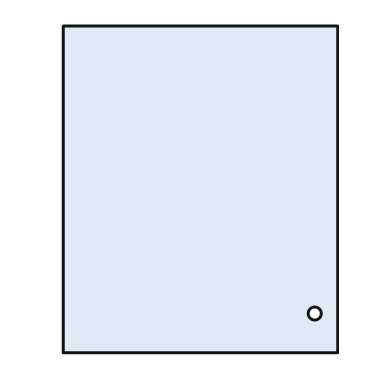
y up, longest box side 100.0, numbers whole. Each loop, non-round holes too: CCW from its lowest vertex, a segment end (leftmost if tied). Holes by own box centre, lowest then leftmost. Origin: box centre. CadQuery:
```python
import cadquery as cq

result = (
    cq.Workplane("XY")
    .moveTo(-42.0, -50.0)
    .lineTo(42.0, -50.0)
    .lineTo(42.0, 50.0)
    .lineTo(-42.0, 50.0)
    .close()
    .moveTo(35.0, -38.0)
    .circle(2.0)
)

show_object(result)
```